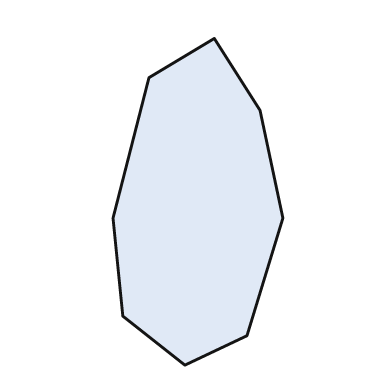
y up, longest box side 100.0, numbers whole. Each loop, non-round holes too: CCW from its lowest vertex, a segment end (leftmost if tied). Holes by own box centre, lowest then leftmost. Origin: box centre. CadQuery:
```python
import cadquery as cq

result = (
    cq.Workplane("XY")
    .moveTo(-4.0, -50.0)
    .lineTo(15.0, -41.0)
    .lineTo(26.0, -5.0)
    .lineTo(19.0, 28.0)
    .lineTo(5.0, 50.0)
    .lineTo(-15.0, 38.0)
    .lineTo(-26.0, -5.0)
    .lineTo(-23.0, -35.0)
    .close()
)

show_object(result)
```